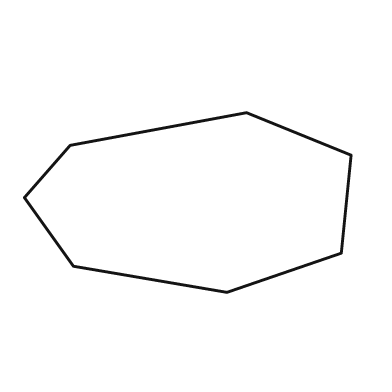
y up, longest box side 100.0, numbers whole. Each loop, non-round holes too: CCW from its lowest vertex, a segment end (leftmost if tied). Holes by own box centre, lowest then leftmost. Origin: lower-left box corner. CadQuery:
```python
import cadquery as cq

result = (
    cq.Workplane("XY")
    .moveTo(62.0, 0.0)
    .lineTo(97.0, 12.0)
    .lineTo(100.0, 42.0)
    .lineTo(68.0, 55.0)
    .lineTo(14.0, 45.0)
    .lineTo(0.0, 29.0)
    .lineTo(15.0, 8.0)
    .close()
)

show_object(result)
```